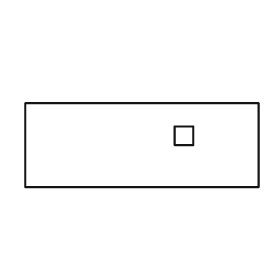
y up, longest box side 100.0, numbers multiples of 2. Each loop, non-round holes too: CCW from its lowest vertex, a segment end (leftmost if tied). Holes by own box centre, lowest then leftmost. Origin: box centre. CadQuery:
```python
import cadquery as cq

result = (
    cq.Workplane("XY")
    .moveTo(-50.0, -18.0)
    .lineTo(50.0, -18.0)
    .lineTo(50.0, 18.0)
    .lineTo(-50.0, 18.0)
    .close()
    .moveTo(14.0, 0.0)
    .lineTo(22.0, 0.0)
    .lineTo(22.0, 8.0)
    .lineTo(14.0, 8.0)
    .close()
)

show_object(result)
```